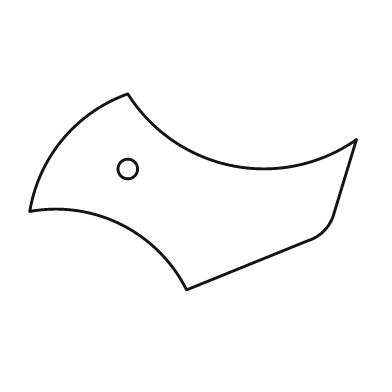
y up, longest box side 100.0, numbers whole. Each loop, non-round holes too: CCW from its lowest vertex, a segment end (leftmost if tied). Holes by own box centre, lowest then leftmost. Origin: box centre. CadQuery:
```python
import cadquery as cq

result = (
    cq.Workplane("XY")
    .moveTo(-2.0, -30.0)
    .lineTo(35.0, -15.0)
    .threePointArc((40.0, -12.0), (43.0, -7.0))
    .lineTo(50.0, 16.0)
    .threePointArc((12.0, 8.0), (-20.0, 30.0))
    .threePointArc((-40.0, 16.0), (-50.0, -6.0))
    .threePointArc((-22.0, -10.0), (-2.0, -30.0))
    .close()
    .moveTo(-20.0, 7.0)
    .circle(3.0)
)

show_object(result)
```